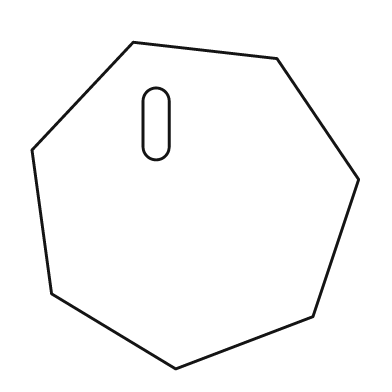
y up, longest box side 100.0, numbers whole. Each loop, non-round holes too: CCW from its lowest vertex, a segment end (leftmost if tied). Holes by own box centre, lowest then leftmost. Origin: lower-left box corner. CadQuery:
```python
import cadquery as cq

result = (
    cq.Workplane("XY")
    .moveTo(44.0, 0.0)
    .lineTo(86.0, 16.0)
    .lineTo(100.0, 58.0)
    .lineTo(75.0, 95.0)
    .lineTo(31.0, 100.0)
    .lineTo(0.0, 67.0)
    .lineTo(6.0, 23.0)
    .close()
    .moveTo(34.0, 68.0)
    .threePointArc((38.0, 64.0), (42.0, 68.0))
    .lineTo(42.0, 82.0)
    .threePointArc((38.0, 86.0), (34.0, 82.0))
    .close()
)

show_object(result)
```